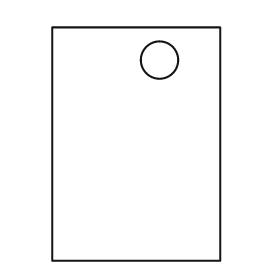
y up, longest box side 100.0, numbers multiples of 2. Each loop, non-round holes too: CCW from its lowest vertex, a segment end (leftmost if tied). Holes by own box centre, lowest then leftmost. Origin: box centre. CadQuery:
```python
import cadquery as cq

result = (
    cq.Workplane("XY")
    .moveTo(-36.0, -50.0)
    .lineTo(36.0, -50.0)
    .lineTo(36.0, 50.0)
    .lineTo(-36.0, 50.0)
    .close()
    .moveTo(10.0, 36.0)
    .circle(8.0)
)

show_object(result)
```